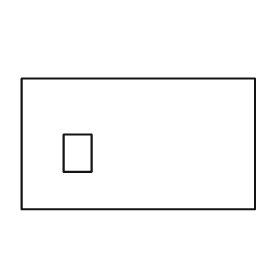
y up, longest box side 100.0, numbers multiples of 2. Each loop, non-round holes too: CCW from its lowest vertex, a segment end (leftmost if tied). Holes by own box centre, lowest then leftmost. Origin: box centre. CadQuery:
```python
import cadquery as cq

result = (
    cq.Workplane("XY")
    .moveTo(-50.0, -28.0)
    .lineTo(50.0, -28.0)
    .lineTo(50.0, 28.0)
    .lineTo(-50.0, 28.0)
    .close()
    .moveTo(-32.0, -12.0)
    .lineTo(-20.0, -12.0)
    .lineTo(-20.0, 4.0)
    .lineTo(-32.0, 4.0)
    .close()
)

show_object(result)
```